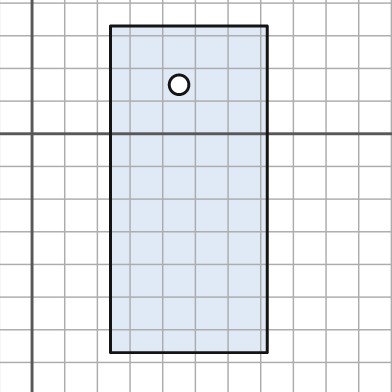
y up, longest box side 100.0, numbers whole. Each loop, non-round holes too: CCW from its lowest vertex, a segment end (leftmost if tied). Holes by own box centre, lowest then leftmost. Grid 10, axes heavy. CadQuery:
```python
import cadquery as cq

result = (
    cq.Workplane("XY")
    .moveTo(24.0, -67.0)
    .lineTo(72.0, -67.0)
    .lineTo(72.0, 33.0)
    .lineTo(24.0, 33.0)
    .close()
    .moveTo(45.0, 15.0)
    .circle(3.0)
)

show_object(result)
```